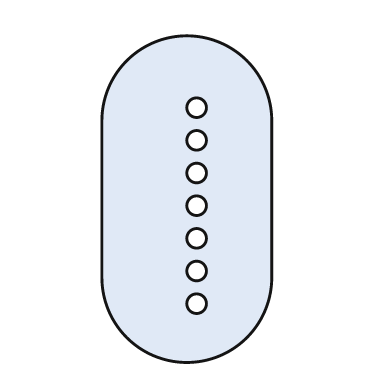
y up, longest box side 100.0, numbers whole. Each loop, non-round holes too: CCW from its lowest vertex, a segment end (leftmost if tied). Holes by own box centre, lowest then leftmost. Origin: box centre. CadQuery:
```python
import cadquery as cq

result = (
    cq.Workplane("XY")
    .moveTo(-26.0, -24.0)
    .threePointArc((0.0, -50.0), (26.0, -24.0))
    .lineTo(26.0, 24.0)
    .threePointArc((0.0, 50.0), (-26.0, 24.0))
    .close()
    .moveTo(3.0, -32.0)
    .circle(3.0)
    .moveTo(3.0, -22.0)
    .circle(3.0)
    .moveTo(3.0, -12.0)
    .circle(3.0)
    .moveTo(3.0, -2.0)
    .circle(3.0)
    .moveTo(3.0, 8.0)
    .circle(3.0)
    .moveTo(3.0, 18.0)
    .circle(3.0)
    .moveTo(3.0, 28.0)
    .circle(3.0)
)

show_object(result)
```